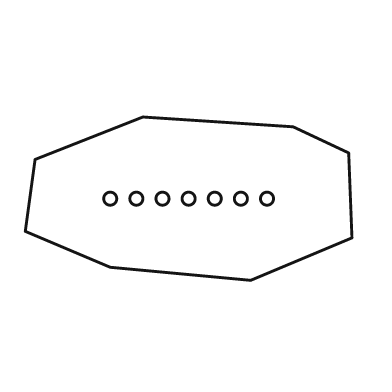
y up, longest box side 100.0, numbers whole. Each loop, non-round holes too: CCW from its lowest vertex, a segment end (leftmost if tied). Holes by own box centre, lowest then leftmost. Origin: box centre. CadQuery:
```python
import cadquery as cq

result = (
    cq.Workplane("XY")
    .moveTo(19.0, -25.0)
    .lineTo(50.0, -12.0)
    .lineTo(49.0, 14.0)
    .lineTo(32.0, 22.0)
    .lineTo(-14.0, 25.0)
    .lineTo(-47.0, 12.0)
    .lineTo(-50.0, -10.0)
    .lineTo(-24.0, -21.0)
    .close()
    .moveTo(-24.0, 0.0)
    .circle(2.0)
    .moveTo(-16.0, 0.0)
    .circle(2.0)
    .moveTo(-8.0, 0.0)
    .circle(2.0)
    .moveTo(0.0, 0.0)
    .circle(2.0)
    .moveTo(8.0, 0.0)
    .circle(2.0)
    .moveTo(16.0, 0.0)
    .circle(2.0)
    .moveTo(24.0, 0.0)
    .circle(2.0)
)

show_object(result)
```